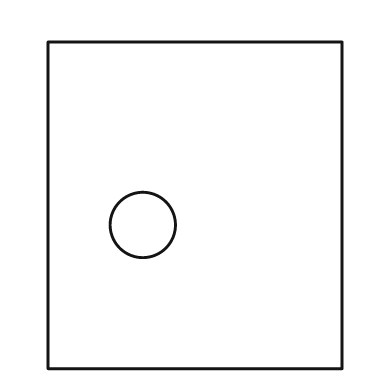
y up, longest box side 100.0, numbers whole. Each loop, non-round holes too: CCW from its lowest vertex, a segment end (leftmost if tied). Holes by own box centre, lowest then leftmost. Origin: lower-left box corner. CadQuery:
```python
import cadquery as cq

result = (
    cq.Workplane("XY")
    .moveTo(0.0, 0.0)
    .lineTo(90.0, 0.0)
    .lineTo(90.0, 100.0)
    .lineTo(0.0, 100.0)
    .close()
    .moveTo(29.0, 44.0)
    .circle(10.0)
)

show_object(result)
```